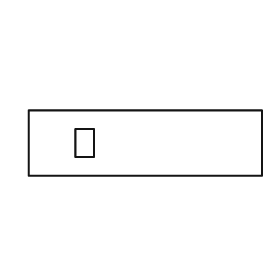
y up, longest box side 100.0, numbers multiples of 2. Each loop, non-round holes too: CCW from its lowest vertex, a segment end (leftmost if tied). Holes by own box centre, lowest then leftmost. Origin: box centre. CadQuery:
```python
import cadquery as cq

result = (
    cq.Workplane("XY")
    .moveTo(-50.0, -14.0)
    .lineTo(50.0, -14.0)
    .lineTo(50.0, 14.0)
    .lineTo(-50.0, 14.0)
    .close()
    .moveTo(-30.0, -6.0)
    .lineTo(-22.0, -6.0)
    .lineTo(-22.0, 6.0)
    .lineTo(-30.0, 6.0)
    .close()
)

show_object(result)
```